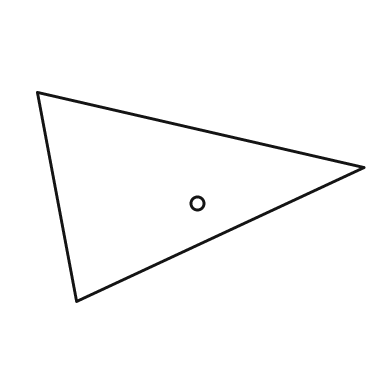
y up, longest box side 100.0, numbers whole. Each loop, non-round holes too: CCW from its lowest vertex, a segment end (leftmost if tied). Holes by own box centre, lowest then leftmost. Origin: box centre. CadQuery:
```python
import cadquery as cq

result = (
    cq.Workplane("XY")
    .moveTo(-38.0, -32.0)
    .lineTo(50.0, 9.0)
    .lineTo(-50.0, 32.0)
    .close()
    .moveTo(-1.0, -2.0)
    .circle(2.0)
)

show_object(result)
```